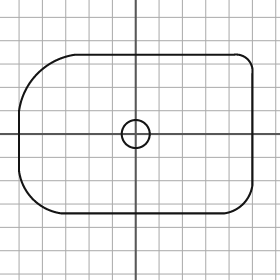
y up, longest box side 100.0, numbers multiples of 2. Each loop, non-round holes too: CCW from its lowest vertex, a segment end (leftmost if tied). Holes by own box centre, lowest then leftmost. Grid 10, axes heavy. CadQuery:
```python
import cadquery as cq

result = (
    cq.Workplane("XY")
    .moveTo(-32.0, -34.0)
    .lineTo(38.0, -34.0)
    .threePointArc((46.0, -30.0), (50.0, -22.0))
    .lineTo(50.0, 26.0)
    .threePointArc((48.0, 32.0), (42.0, 34.0))
    .lineTo(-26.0, 34.0)
    .threePointArc((-42.0, 26.0), (-50.0, 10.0))
    .lineTo(-50.0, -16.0)
    .threePointArc((-44.0, -28.0), (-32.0, -34.0))
    .close()
    .moveTo(0.0, 0.0)
    .circle(6.0)
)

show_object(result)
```